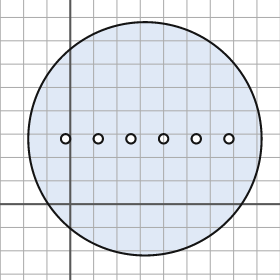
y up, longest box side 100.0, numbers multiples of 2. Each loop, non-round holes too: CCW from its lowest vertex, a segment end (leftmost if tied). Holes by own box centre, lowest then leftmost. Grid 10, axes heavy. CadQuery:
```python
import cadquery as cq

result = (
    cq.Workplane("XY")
    .moveTo(32.0, 28.0)
    .circle(50.0)
    .moveTo(-2.0, 28.0)
    .circle(2.0)
    .moveTo(12.0, 28.0)
    .circle(2.0)
    .moveTo(26.0, 28.0)
    .circle(2.0)
    .moveTo(40.0, 28.0)
    .circle(2.0)
    .moveTo(54.0, 28.0)
    .circle(2.0)
    .moveTo(68.0, 28.0)
    .circle(2.0)
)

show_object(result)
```